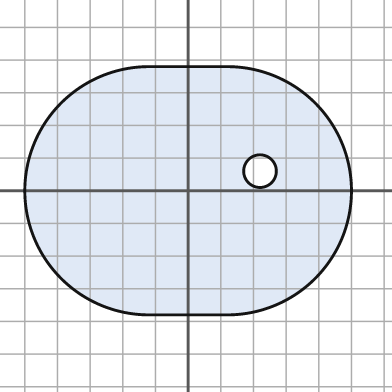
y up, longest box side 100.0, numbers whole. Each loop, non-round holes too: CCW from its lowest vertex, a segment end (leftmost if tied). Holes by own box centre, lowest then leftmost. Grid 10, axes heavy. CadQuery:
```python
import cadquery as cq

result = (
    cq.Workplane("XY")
    .moveTo(-12.0, -38.0)
    .lineTo(12.0, -38.0)
    .threePointArc((50.0, 0.0), (12.0, 38.0))
    .lineTo(-12.0, 38.0)
    .threePointArc((-50.0, 0.0), (-12.0, -38.0))
    .close()
    .moveTo(22.0, 6.0)
    .circle(5.0)
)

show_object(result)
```